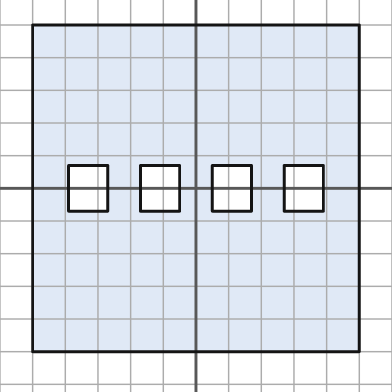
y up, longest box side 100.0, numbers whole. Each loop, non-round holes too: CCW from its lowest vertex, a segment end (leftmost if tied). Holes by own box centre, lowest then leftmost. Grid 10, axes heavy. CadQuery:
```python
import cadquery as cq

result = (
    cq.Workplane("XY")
    .moveTo(-50.0, -50.0)
    .lineTo(50.0, -50.0)
    .lineTo(50.0, 50.0)
    .lineTo(-50.0, 50.0)
    .close()
    .moveTo(-39.0, -7.0)
    .lineTo(-27.0, -7.0)
    .lineTo(-27.0, 7.0)
    .lineTo(-39.0, 7.0)
    .close()
    .moveTo(-17.0, -7.0)
    .lineTo(-5.0, -7.0)
    .lineTo(-5.0, 7.0)
    .lineTo(-17.0, 7.0)
    .close()
    .moveTo(5.0, -7.0)
    .lineTo(17.0, -7.0)
    .lineTo(17.0, 7.0)
    .lineTo(5.0, 7.0)
    .close()
    .moveTo(27.0, -7.0)
    .lineTo(39.0, -7.0)
    .lineTo(39.0, 7.0)
    .lineTo(27.0, 7.0)
    .close()
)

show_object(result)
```